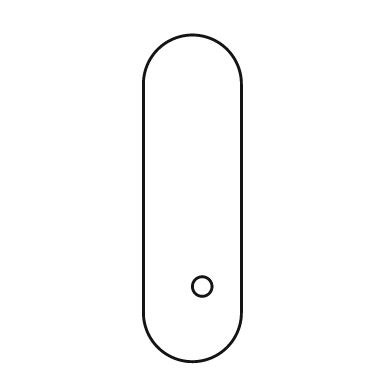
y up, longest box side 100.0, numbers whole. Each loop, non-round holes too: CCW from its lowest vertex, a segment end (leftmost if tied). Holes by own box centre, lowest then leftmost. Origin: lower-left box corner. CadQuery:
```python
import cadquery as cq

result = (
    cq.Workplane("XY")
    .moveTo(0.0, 15.0)
    .threePointArc((15.0, 0.0), (30.0, 15.0))
    .lineTo(30.0, 85.0)
    .threePointArc((15.0, 100.0), (0.0, 85.0))
    .close()
    .moveTo(18.0, 23.0)
    .circle(3.0)
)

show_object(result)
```